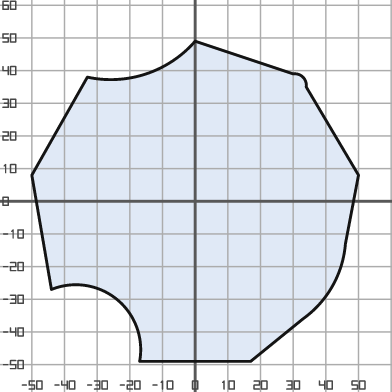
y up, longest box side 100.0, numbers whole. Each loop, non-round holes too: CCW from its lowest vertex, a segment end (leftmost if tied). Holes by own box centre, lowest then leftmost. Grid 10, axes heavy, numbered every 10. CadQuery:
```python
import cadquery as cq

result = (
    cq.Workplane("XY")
    .moveTo(-17.0, -49.0)
    .lineTo(17.0, -49.0)
    .lineTo(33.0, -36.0)
    .threePointArc((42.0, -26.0), (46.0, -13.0))
    .lineTo(50.0, 8.0)
    .lineTo(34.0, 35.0)
    .threePointArc((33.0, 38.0), (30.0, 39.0))
    .lineTo(0.0, 49.0)
    .threePointArc((-15.0, 39.0), (-33.0, 38.0))
    .lineTo(-50.0, 8.0)
    .lineTo(-44.0, -27.0)
    .threePointArc((-24.0, -30.0), (-17.0, -49.0))
    .close()
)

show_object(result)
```